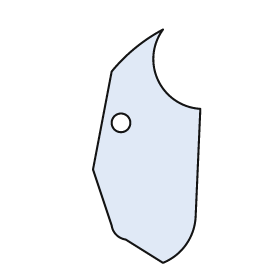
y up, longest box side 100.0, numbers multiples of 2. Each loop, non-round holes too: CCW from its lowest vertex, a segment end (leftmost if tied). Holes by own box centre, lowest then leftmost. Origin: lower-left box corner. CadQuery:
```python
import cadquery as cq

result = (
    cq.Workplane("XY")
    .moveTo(30.0, 0.0)
    .threePointArc((40.0, 8.0), (44.0, 20.0))
    .lineTo(46.0, 66.0)
    .threePointArc((28.0, 78.0), (30.0, 100.0))
    .threePointArc((18.0, 92.0), (8.0, 82.0))
    .lineTo(0.0, 40.0)
    .lineTo(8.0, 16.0)
    .threePointArc((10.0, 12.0), (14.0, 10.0))
    .close()
    .moveTo(12.0, 60.0)
    .circle(4.0)
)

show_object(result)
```